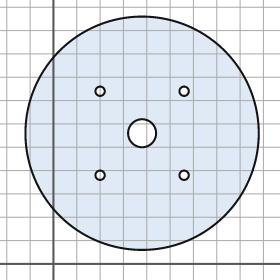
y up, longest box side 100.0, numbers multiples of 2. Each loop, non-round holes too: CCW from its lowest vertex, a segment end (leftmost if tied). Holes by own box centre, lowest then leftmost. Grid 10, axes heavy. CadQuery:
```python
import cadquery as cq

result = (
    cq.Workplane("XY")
    .moveTo(38.0, 56.0)
    .circle(50.0)
    .moveTo(20.0, 38.0)
    .circle(2.0)
    .moveTo(56.0, 38.0)
    .circle(2.0)
    .moveTo(38.0, 56.0)
    .circle(6.0)
    .moveTo(20.0, 74.0)
    .circle(2.0)
    .moveTo(56.0, 74.0)
    .circle(2.0)
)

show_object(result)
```